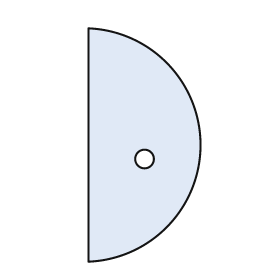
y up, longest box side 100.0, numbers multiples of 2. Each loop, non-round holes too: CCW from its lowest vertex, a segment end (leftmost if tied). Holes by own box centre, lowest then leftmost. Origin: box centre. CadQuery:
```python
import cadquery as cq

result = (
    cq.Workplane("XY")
    .moveTo(-24.0, -50.0)
    .threePointArc((24.0, 0.0), (-24.0, 50.0))
    .close()
    .moveTo(0.0, -6.0)
    .circle(4.0)
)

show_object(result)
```